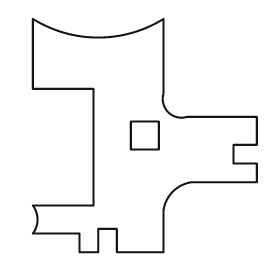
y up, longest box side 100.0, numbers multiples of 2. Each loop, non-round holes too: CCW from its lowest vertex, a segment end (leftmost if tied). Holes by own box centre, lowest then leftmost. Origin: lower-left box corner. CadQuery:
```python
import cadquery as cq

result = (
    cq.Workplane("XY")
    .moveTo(20.0, 0.0)
    .lineTo(28.0, 0.0)
    .lineTo(28.0, 10.0)
    .lineTo(36.0, 10.0)
    .lineTo(36.0, 0.0)
    .lineTo(56.0, 0.0)
    .lineTo(56.0, 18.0)
    .threePointArc((60.0, 26.0), (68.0, 30.0))
    .lineTo(96.0, 30.0)
    .lineTo(96.0, 38.0)
    .lineTo(86.0, 38.0)
    .lineTo(86.0, 46.0)
    .lineTo(96.0, 46.0)
    .lineTo(96.0, 58.0)
    .lineTo(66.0, 58.0)
    .threePointArc((58.0, 60.0), (56.0, 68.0))
    .lineTo(56.0, 100.0)
    .threePointArc((28.0, 92.0), (0.0, 100.0))
    .lineTo(0.0, 70.0)
    .lineTo(26.0, 70.0)
    .lineTo(26.0, 20.0)
    .lineTo(0.0, 20.0)
    .threePointArc((2.0, 14.0), (0.0, 8.0))
    .lineTo(20.0, 8.0)
    .close()
    .moveTo(42.0, 44.0)
    .lineTo(54.0, 44.0)
    .lineTo(54.0, 56.0)
    .lineTo(42.0, 56.0)
    .close()
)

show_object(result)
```